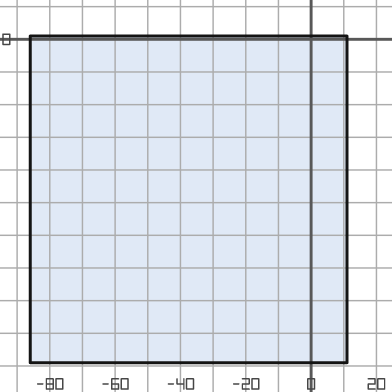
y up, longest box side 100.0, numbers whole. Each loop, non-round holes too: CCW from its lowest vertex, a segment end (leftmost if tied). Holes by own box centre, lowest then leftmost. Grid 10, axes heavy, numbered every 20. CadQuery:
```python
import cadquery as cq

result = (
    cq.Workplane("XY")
    .moveTo(-86.0, -99.0)
    .lineTo(11.0, -99.0)
    .lineTo(11.0, 1.0)
    .lineTo(-86.0, 1.0)
    .close()
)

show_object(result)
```